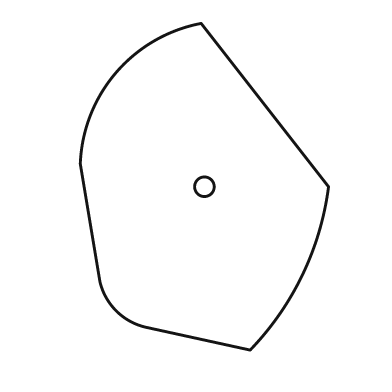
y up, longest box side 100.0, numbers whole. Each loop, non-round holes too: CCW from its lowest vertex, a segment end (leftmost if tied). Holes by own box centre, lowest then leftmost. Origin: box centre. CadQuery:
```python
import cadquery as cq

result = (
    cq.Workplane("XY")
    .moveTo(14.0, -50.0)
    .threePointArc((30.0, -27.0), (38.0, 0.0))
    .lineTo(-1.0, 50.0)
    .threePointArc((-27.0, 35.0), (-38.0, 7.0))
    .lineTo(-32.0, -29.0)
    .threePointArc((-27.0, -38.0), (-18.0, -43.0))
    .close()
    .moveTo(0.0, 0.0)
    .circle(3.0)
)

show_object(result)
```